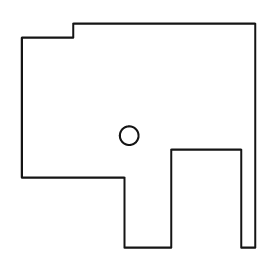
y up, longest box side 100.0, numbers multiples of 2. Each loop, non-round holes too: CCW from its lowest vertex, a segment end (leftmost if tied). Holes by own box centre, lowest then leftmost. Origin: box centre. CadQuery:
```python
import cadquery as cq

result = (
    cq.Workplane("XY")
    .moveTo(-6.0, -48.0)
    .lineTo(14.0, -48.0)
    .lineTo(14.0, -6.0)
    .lineTo(44.0, -6.0)
    .lineTo(44.0, -48.0)
    .lineTo(50.0, -48.0)
    .lineTo(50.0, 48.0)
    .lineTo(-28.0, 48.0)
    .lineTo(-28.0, 42.0)
    .lineTo(-50.0, 42.0)
    .lineTo(-50.0, -18.0)
    .lineTo(-6.0, -18.0)
    .close()
    .moveTo(-4.0, 0.0)
    .circle(4.0)
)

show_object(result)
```